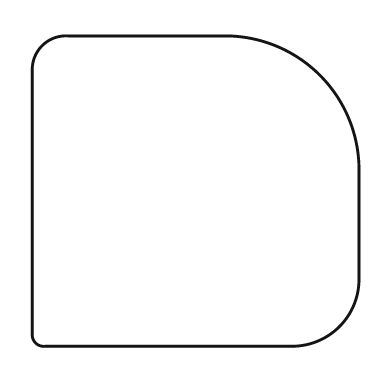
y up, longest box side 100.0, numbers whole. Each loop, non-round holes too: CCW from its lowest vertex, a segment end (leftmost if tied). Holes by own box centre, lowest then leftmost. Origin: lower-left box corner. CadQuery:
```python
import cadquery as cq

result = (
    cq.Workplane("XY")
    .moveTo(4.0, 0.0)
    .lineTo(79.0, 0.0)
    .threePointArc((94.0, 6.0), (100.0, 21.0))
    .lineTo(100.0, 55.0)
    .threePointArc((88.0, 83.0), (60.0, 95.0))
    .lineTo(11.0, 95.0)
    .threePointArc((3.0, 92.0), (0.0, 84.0))
    .lineTo(0.0, 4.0)
    .threePointArc((1.0, 1.0), (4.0, 0.0))
    .close()
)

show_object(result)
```